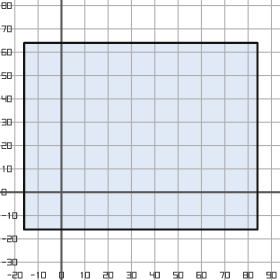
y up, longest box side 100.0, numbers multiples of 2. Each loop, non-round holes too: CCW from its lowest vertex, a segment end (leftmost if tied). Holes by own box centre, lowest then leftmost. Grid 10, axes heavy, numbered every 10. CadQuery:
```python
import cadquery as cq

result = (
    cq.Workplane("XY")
    .moveTo(-16.0, -16.0)
    .lineTo(84.0, -16.0)
    .lineTo(84.0, 64.0)
    .lineTo(-16.0, 64.0)
    .close()
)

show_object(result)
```